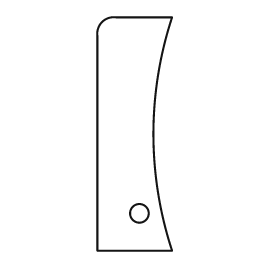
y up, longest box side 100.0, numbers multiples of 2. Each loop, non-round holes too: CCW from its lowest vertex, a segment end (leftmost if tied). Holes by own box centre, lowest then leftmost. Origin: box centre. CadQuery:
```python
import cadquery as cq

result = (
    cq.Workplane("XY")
    .moveTo(-16.0, -50.0)
    .lineTo(16.0, -50.0)
    .threePointArc((8.0, 0.0), (16.0, 50.0))
    .lineTo(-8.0, 50.0)
    .threePointArc((-14.0, 48.0), (-16.0, 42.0))
    .close()
    .moveTo(2.0, -34.0)
    .circle(4.0)
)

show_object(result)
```